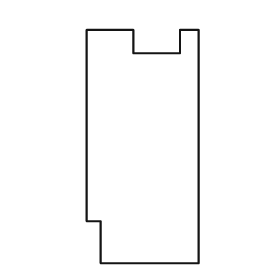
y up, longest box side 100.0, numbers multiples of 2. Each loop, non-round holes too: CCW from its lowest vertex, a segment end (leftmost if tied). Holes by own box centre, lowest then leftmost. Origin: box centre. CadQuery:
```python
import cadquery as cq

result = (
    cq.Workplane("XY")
    .moveTo(-18.0, -50.0)
    .lineTo(24.0, -50.0)
    .lineTo(24.0, 50.0)
    .lineTo(16.0, 50.0)
    .lineTo(16.0, 40.0)
    .lineTo(-4.0, 40.0)
    .lineTo(-4.0, 50.0)
    .lineTo(-24.0, 50.0)
    .lineTo(-24.0, -32.0)
    .lineTo(-18.0, -32.0)
    .close()
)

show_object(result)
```